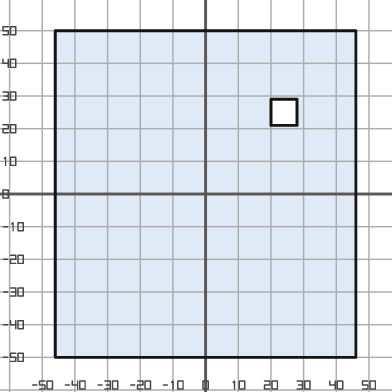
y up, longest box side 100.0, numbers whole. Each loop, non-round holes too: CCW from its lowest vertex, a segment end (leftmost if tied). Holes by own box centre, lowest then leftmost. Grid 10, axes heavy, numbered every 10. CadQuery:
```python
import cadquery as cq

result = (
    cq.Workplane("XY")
    .moveTo(-46.0, -50.0)
    .lineTo(46.0, -50.0)
    .lineTo(46.0, 50.0)
    .lineTo(-46.0, 50.0)
    .close()
    .moveTo(20.0, 21.0)
    .lineTo(28.0, 21.0)
    .lineTo(28.0, 29.0)
    .lineTo(20.0, 29.0)
    .close()
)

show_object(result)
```